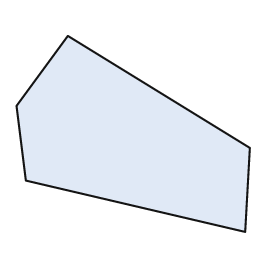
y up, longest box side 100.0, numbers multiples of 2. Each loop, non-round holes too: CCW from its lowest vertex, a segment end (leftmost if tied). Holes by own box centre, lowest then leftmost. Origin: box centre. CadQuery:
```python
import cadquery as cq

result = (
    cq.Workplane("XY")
    .moveTo(48.0, -42.0)
    .lineTo(50.0, -6.0)
    .lineTo(-28.0, 42.0)
    .lineTo(-50.0, 12.0)
    .lineTo(-46.0, -20.0)
    .close()
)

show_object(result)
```